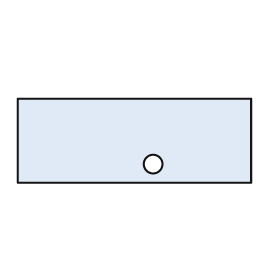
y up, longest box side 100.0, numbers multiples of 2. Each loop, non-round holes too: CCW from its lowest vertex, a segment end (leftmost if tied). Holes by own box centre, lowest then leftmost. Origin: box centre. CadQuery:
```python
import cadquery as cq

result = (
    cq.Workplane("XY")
    .moveTo(-50.0, -18.0)
    .lineTo(50.0, -18.0)
    .lineTo(50.0, 18.0)
    .lineTo(-50.0, 18.0)
    .close()
    .moveTo(8.0, -10.0)
    .circle(4.0)
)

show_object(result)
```